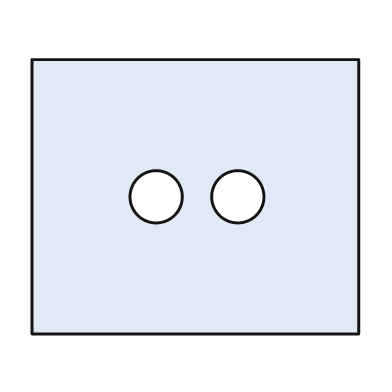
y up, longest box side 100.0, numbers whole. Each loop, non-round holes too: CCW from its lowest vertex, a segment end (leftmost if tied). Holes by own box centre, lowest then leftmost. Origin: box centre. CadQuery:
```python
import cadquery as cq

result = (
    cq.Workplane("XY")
    .moveTo(-50.0, -42.0)
    .lineTo(50.0, -42.0)
    .lineTo(50.0, 42.0)
    .lineTo(-50.0, 42.0)
    .close()
    .moveTo(-12.0, 0.0)
    .circle(8.0)
    .moveTo(13.0, 0.0)
    .circle(8.0)
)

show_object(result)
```